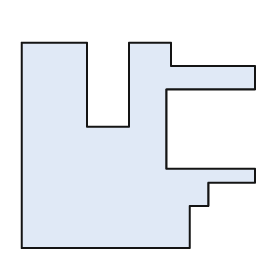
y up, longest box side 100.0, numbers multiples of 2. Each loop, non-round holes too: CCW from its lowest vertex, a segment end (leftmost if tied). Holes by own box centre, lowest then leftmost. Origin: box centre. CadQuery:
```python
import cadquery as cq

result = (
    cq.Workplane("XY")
    .moveTo(-50.0, -44.0)
    .lineTo(22.0, -44.0)
    .lineTo(22.0, -26.0)
    .lineTo(30.0, -26.0)
    .lineTo(30.0, -16.0)
    .lineTo(50.0, -16.0)
    .lineTo(50.0, -10.0)
    .lineTo(12.0, -10.0)
    .lineTo(12.0, 24.0)
    .lineTo(50.0, 24.0)
    .lineTo(50.0, 34.0)
    .lineTo(14.0, 34.0)
    .lineTo(14.0, 44.0)
    .lineTo(-4.0, 44.0)
    .lineTo(-4.0, 8.0)
    .lineTo(-22.0, 8.0)
    .lineTo(-22.0, 44.0)
    .lineTo(-50.0, 44.0)
    .close()
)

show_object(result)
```